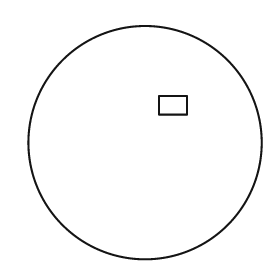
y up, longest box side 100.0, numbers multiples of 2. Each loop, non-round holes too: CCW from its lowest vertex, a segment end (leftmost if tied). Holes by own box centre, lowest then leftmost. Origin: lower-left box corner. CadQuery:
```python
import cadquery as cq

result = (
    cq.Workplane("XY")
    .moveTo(50.0, 50.0)
    .circle(50.0)
    .moveTo(56.0, 62.0)
    .lineTo(68.0, 62.0)
    .lineTo(68.0, 70.0)
    .lineTo(56.0, 70.0)
    .close()
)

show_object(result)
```